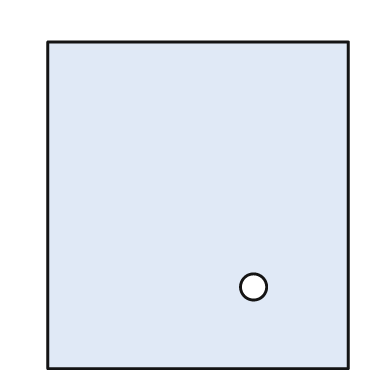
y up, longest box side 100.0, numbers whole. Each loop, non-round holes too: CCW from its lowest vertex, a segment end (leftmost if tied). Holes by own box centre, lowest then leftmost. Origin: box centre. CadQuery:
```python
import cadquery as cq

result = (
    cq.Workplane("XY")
    .moveTo(-46.0, -50.0)
    .lineTo(46.0, -50.0)
    .lineTo(46.0, 50.0)
    .lineTo(-46.0, 50.0)
    .close()
    .moveTo(17.0, -25.0)
    .circle(4.0)
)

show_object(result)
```